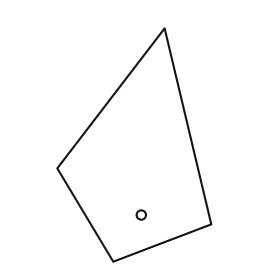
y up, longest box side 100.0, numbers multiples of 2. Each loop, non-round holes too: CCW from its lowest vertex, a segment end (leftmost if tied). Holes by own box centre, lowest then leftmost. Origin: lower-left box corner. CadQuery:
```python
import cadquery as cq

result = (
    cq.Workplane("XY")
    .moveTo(24.0, 0.0)
    .lineTo(66.0, 16.0)
    .lineTo(46.0, 100.0)
    .lineTo(0.0, 40.0)
    .close()
    .moveTo(36.0, 20.0)
    .circle(2.0)
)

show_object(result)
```